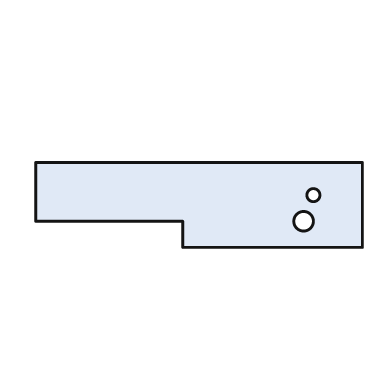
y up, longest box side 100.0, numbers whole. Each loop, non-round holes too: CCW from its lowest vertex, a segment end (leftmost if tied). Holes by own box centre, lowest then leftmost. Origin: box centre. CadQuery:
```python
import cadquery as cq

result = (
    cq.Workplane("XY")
    .moveTo(-5.0, -13.0)
    .lineTo(50.0, -13.0)
    .lineTo(50.0, 13.0)
    .lineTo(-50.0, 13.0)
    .lineTo(-50.0, -5.0)
    .lineTo(-5.0, -5.0)
    .close()
    .moveTo(32.0, -5.0)
    .circle(3.0)
    .moveTo(35.0, 3.0)
    .circle(2.0)
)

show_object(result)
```